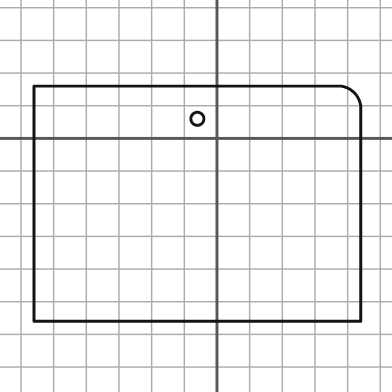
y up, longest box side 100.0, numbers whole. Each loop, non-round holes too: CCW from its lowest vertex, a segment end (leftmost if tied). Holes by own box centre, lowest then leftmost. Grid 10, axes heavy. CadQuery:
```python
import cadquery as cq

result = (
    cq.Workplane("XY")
    .moveTo(-56.0, -56.0)
    .lineTo(44.0, -56.0)
    .lineTo(44.0, 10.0)
    .threePointArc((42.0, 14.0), (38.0, 16.0))
    .lineTo(-56.0, 16.0)
    .close()
    .moveTo(-6.0, 6.0)
    .circle(2.0)
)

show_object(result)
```